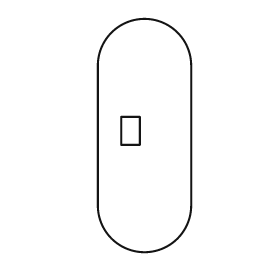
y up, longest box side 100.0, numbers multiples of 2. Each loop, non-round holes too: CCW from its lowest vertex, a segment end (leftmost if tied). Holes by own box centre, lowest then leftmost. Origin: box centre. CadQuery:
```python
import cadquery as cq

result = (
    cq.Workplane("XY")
    .moveTo(-20.0, -30.0)
    .threePointArc((0.0, -50.0), (20.0, -30.0))
    .lineTo(20.0, 30.0)
    .threePointArc((0.0, 50.0), (-20.0, 30.0))
    .close()
    .moveTo(-10.0, -4.0)
    .lineTo(-2.0, -4.0)
    .lineTo(-2.0, 8.0)
    .lineTo(-10.0, 8.0)
    .close()
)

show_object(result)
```